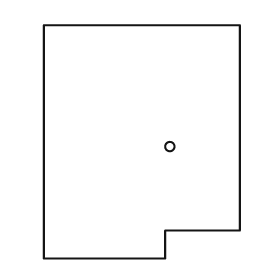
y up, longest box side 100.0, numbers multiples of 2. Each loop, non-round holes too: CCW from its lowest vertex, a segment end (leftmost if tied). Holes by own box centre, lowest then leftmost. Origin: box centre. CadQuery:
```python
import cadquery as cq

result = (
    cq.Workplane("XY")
    .moveTo(-42.0, -50.0)
    .lineTo(10.0, -50.0)
    .lineTo(10.0, -38.0)
    .lineTo(42.0, -38.0)
    .lineTo(42.0, 50.0)
    .lineTo(-42.0, 50.0)
    .close()
    .moveTo(12.0, -2.0)
    .circle(2.0)
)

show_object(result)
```